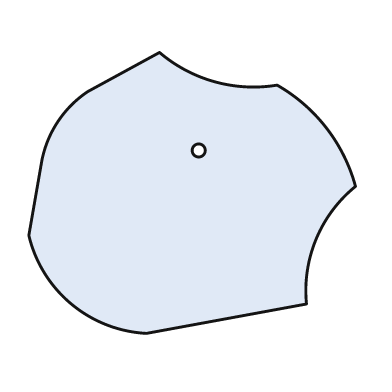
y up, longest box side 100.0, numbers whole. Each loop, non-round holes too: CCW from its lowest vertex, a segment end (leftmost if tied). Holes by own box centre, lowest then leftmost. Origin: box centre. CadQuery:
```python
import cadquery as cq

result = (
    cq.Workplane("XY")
    .moveTo(-14.0, -43.0)
    .lineTo(35.0, -34.0)
    .threePointArc((38.0, -14.0), (50.0, 2.0))
    .threePointArc((41.0, 20.0), (26.0, 33.0))
    .threePointArc((7.0, 34.0), (-10.0, 43.0))
    .lineTo(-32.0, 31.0)
    .threePointArc((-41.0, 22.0), (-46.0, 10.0))
    .lineTo(-50.0, -13.0)
    .threePointArc((-37.0, -34.0), (-14.0, -43.0))
    .close()
    .moveTo(2.0, 13.0)
    .circle(2.0)
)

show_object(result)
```